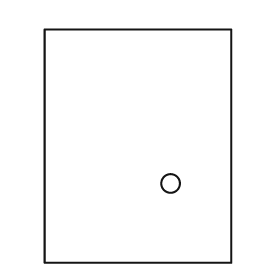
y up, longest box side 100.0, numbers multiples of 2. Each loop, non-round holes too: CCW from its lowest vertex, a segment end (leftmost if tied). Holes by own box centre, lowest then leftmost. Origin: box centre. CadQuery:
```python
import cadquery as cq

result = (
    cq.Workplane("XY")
    .moveTo(-40.0, -50.0)
    .lineTo(40.0, -50.0)
    .lineTo(40.0, 50.0)
    .lineTo(-40.0, 50.0)
    .close()
    .moveTo(14.0, -16.0)
    .circle(4.0)
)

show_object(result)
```